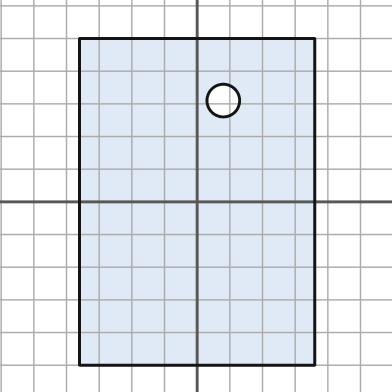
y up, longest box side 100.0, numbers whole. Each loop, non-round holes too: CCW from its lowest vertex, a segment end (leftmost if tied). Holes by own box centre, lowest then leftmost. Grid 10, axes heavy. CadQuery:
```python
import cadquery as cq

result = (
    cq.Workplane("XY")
    .moveTo(-36.0, -50.0)
    .lineTo(36.0, -50.0)
    .lineTo(36.0, 50.0)
    .lineTo(-36.0, 50.0)
    .close()
    .moveTo(8.0, 31.0)
    .circle(5.0)
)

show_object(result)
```